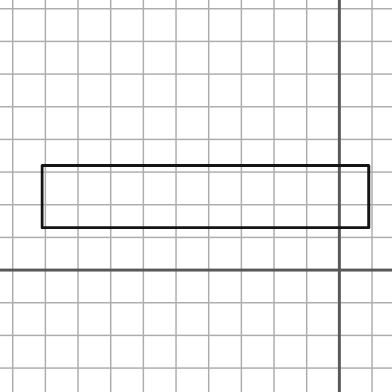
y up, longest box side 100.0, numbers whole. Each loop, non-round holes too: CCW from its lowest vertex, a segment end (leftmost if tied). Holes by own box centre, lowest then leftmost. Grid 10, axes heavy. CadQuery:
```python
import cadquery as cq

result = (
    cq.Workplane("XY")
    .moveTo(-91.0, 13.0)
    .lineTo(9.0, 13.0)
    .lineTo(9.0, 32.0)
    .lineTo(-91.0, 32.0)
    .close()
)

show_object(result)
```